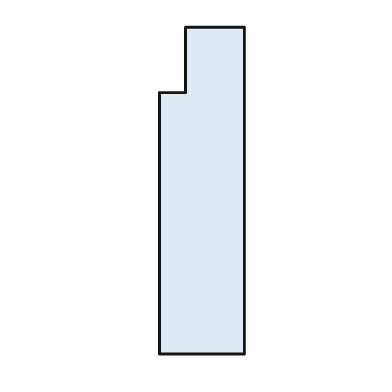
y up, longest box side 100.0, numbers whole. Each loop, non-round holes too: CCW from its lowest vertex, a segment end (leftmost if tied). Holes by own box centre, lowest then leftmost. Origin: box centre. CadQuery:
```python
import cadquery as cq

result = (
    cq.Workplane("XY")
    .moveTo(-13.0, -50.0)
    .lineTo(13.0, -50.0)
    .lineTo(13.0, 50.0)
    .lineTo(-5.0, 50.0)
    .lineTo(-5.0, 30.0)
    .lineTo(-13.0, 30.0)
    .close()
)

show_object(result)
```